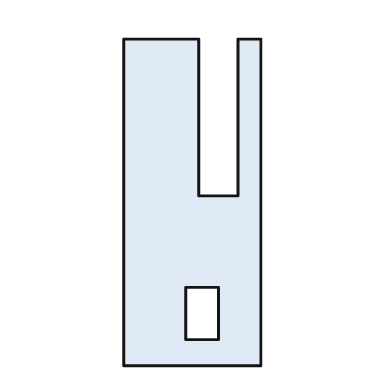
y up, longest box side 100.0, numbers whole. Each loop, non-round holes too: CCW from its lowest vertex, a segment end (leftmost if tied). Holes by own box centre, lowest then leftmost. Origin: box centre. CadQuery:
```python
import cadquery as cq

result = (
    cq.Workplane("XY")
    .moveTo(-21.0, -50.0)
    .lineTo(21.0, -50.0)
    .lineTo(21.0, 50.0)
    .lineTo(14.0, 50.0)
    .lineTo(14.0, 2.0)
    .lineTo(2.0, 2.0)
    .lineTo(2.0, 50.0)
    .lineTo(-21.0, 50.0)
    .close()
    .moveTo(-2.0, -42.0)
    .lineTo(8.0, -42.0)
    .lineTo(8.0, -26.0)
    .lineTo(-2.0, -26.0)
    .close()
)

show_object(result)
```